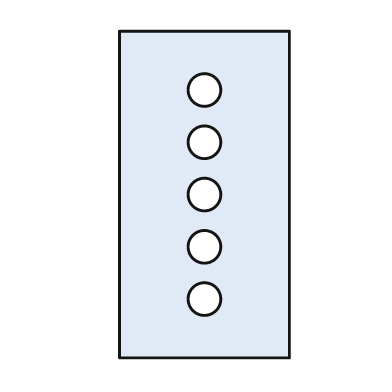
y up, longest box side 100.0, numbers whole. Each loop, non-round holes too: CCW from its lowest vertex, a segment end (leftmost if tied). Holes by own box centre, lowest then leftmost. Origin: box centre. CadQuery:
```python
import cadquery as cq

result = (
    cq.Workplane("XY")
    .moveTo(-26.0, -50.0)
    .lineTo(26.0, -50.0)
    .lineTo(26.0, 50.0)
    .lineTo(-26.0, 50.0)
    .close()
    .moveTo(0.0, -32.0)
    .circle(5.0)
    .moveTo(0.0, -16.0)
    .circle(5.0)
    .moveTo(0.0, 0.0)
    .circle(5.0)
    .moveTo(0.0, 16.0)
    .circle(5.0)
    .moveTo(0.0, 32.0)
    .circle(5.0)
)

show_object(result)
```